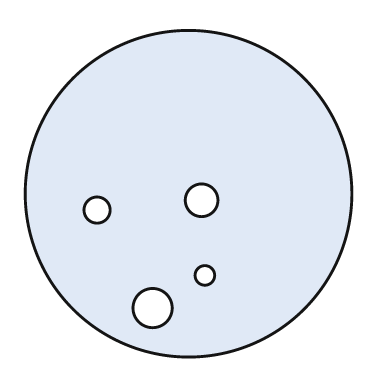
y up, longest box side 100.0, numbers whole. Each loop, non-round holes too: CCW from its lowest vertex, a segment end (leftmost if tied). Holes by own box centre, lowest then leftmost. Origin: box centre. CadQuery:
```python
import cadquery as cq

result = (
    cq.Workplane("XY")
    .moveTo(0.0, 0.0)
    .circle(50.0)
    .moveTo(-11.0, -35.0)
    .circle(6.0)
    .moveTo(5.0, -25.0)
    .circle(3.0)
    .moveTo(-28.0, -5.0)
    .circle(4.0)
    .moveTo(4.0, -2.0)
    .circle(5.0)
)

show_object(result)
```